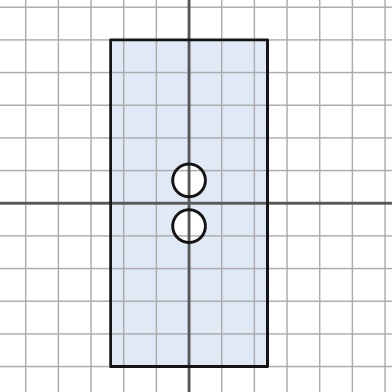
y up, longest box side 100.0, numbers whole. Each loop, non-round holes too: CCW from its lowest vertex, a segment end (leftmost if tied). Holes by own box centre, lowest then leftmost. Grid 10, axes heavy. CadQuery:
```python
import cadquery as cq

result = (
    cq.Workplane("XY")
    .moveTo(-24.0, -50.0)
    .lineTo(24.0, -50.0)
    .lineTo(24.0, 50.0)
    .lineTo(-24.0, 50.0)
    .close()
    .moveTo(0.0, -7.0)
    .circle(5.0)
    .moveTo(0.0, 7.0)
    .circle(5.0)
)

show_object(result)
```